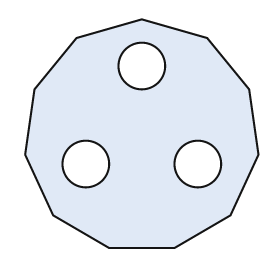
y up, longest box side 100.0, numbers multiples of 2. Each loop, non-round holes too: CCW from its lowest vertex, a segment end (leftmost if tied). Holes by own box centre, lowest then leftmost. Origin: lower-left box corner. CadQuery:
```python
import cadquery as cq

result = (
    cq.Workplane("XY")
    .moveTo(36.0, 0.0)
    .lineTo(64.0, 0.0)
    .lineTo(88.0, 14.0)
    .lineTo(100.0, 40.0)
    .lineTo(96.0, 68.0)
    .lineTo(78.0, 90.0)
    .lineTo(50.0, 98.0)
    .lineTo(22.0, 90.0)
    .lineTo(4.0, 68.0)
    .lineTo(0.0, 40.0)
    .lineTo(12.0, 14.0)
    .close()
    .moveTo(26.0, 36.0)
    .circle(10.0)
    .moveTo(74.0, 36.0)
    .circle(10.0)
    .moveTo(50.0, 78.0)
    .circle(10.0)
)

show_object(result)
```